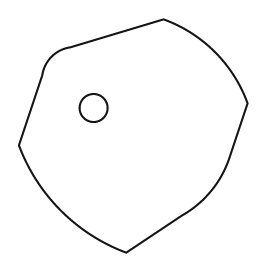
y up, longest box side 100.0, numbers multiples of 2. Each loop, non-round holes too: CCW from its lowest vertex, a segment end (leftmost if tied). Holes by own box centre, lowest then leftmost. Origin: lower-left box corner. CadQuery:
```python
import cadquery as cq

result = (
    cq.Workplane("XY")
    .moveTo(46.0, 0.0)
    .lineTo(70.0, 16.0)
    .threePointArc((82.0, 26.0), (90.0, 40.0))
    .lineTo(98.0, 64.0)
    .threePointArc((84.0, 86.0), (62.0, 100.0))
    .lineTo(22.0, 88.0)
    .threePointArc((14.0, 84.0), (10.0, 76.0))
    .lineTo(0.0, 46.0)
    .threePointArc((18.0, 18.0), (46.0, 0.0))
    .close()
    .moveTo(32.0, 62.0)
    .circle(6.0)
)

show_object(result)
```